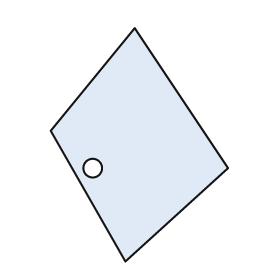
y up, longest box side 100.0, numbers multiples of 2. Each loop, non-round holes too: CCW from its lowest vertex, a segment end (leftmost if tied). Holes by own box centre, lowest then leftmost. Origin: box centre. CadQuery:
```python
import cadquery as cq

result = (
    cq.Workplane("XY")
    .moveTo(-6.0, -50.0)
    .lineTo(38.0, -10.0)
    .lineTo(-2.0, 50.0)
    .lineTo(-38.0, 6.0)
    .close()
    .moveTo(-20.0, -10.0)
    .circle(4.0)
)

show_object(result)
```